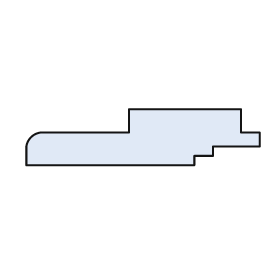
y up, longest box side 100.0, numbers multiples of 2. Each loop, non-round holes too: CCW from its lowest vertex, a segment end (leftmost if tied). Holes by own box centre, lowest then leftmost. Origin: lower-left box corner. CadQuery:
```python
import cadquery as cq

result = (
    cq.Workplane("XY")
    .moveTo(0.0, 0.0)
    .lineTo(72.0, 0.0)
    .lineTo(72.0, 4.0)
    .lineTo(80.0, 4.0)
    .lineTo(80.0, 8.0)
    .lineTo(100.0, 8.0)
    .lineTo(100.0, 14.0)
    .lineTo(92.0, 14.0)
    .lineTo(92.0, 24.0)
    .lineTo(44.0, 24.0)
    .lineTo(44.0, 14.0)
    .lineTo(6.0, 14.0)
    .threePointArc((2.0, 12.0), (0.0, 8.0))
    .close()
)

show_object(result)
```